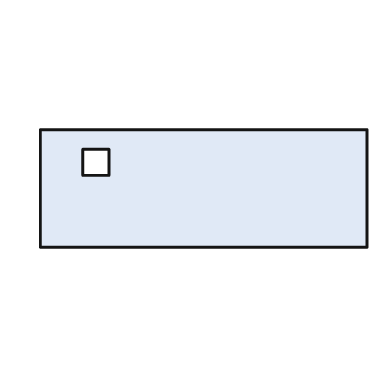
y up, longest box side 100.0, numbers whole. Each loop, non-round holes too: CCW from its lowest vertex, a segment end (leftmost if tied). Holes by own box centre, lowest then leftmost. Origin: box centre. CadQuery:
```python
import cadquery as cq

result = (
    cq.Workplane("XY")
    .moveTo(-50.0, -18.0)
    .lineTo(50.0, -18.0)
    .lineTo(50.0, 18.0)
    .lineTo(-50.0, 18.0)
    .close()
    .moveTo(-37.0, 4.0)
    .lineTo(-29.0, 4.0)
    .lineTo(-29.0, 12.0)
    .lineTo(-37.0, 12.0)
    .close()
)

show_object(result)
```